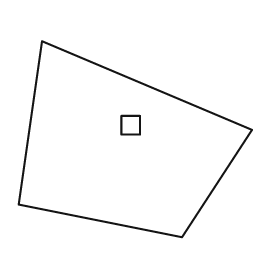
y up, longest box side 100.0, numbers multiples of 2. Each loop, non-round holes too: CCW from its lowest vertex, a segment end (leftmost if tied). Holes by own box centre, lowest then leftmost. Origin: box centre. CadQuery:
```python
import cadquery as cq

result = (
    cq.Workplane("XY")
    .moveTo(20.0, -42.0)
    .lineTo(50.0, 4.0)
    .lineTo(-40.0, 42.0)
    .lineTo(-50.0, -28.0)
    .close()
    .moveTo(-6.0, 2.0)
    .lineTo(2.0, 2.0)
    .lineTo(2.0, 10.0)
    .lineTo(-6.0, 10.0)
    .close()
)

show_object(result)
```